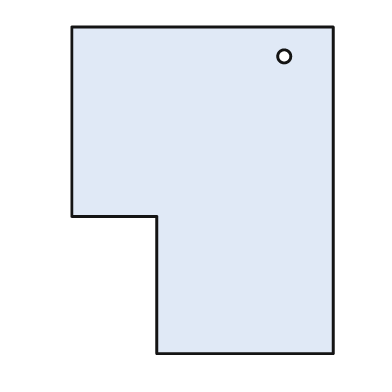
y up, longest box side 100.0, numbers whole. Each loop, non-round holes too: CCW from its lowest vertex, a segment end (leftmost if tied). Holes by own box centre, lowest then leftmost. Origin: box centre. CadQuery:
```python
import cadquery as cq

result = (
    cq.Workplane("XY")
    .moveTo(-14.0, -50.0)
    .lineTo(40.0, -50.0)
    .lineTo(40.0, 50.0)
    .lineTo(-40.0, 50.0)
    .lineTo(-40.0, -8.0)
    .lineTo(-14.0, -8.0)
    .close()
    .moveTo(25.0, 41.0)
    .circle(2.0)
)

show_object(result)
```